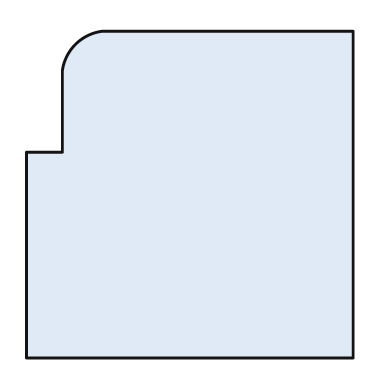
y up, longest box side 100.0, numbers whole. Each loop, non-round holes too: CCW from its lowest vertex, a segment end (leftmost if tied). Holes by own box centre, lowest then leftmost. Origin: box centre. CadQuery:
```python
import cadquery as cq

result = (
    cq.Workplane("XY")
    .moveTo(-50.0, -50.0)
    .lineTo(50.0, -50.0)
    .lineTo(50.0, 50.0)
    .lineTo(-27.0, 50.0)
    .threePointArc((-35.0, 46.0), (-39.0, 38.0))
    .lineTo(-39.0, 13.0)
    .lineTo(-50.0, 13.0)
    .close()
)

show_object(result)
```